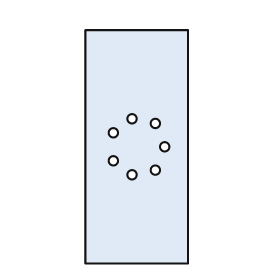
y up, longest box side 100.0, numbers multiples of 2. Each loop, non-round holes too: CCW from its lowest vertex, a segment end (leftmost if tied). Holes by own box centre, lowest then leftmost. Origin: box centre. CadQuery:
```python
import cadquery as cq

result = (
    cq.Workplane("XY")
    .moveTo(-22.0, -50.0)
    .lineTo(22.0, -50.0)
    .lineTo(22.0, 50.0)
    .lineTo(-22.0, 50.0)
    .close()
    .moveTo(-2.0, -12.0)
    .circle(2.0)
    .moveTo(8.0, -10.0)
    .circle(2.0)
    .moveTo(-10.0, -6.0)
    .circle(2.0)
    .moveTo(12.0, 0.0)
    .circle(2.0)
    .moveTo(-10.0, 6.0)
    .circle(2.0)
    .moveTo(8.0, 10.0)
    .circle(2.0)
    .moveTo(-2.0, 12.0)
    .circle(2.0)
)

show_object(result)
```